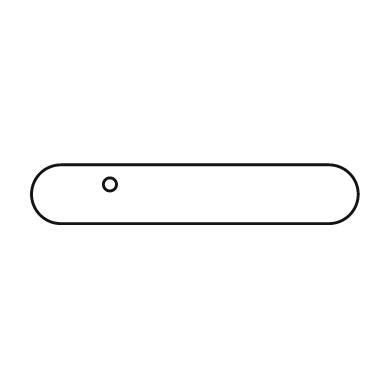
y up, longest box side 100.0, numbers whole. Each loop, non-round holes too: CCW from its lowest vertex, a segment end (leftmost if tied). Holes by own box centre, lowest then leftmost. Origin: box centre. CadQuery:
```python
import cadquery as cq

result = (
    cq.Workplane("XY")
    .moveTo(-41.0, -9.0)
    .lineTo(41.0, -9.0)
    .threePointArc((50.0, 0.0), (41.0, 9.0))
    .lineTo(-41.0, 9.0)
    .threePointArc((-50.0, 0.0), (-41.0, -9.0))
    .close()
    .moveTo(-26.0, 3.0)
    .circle(2.0)
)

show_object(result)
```